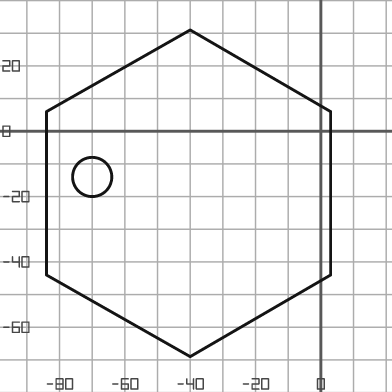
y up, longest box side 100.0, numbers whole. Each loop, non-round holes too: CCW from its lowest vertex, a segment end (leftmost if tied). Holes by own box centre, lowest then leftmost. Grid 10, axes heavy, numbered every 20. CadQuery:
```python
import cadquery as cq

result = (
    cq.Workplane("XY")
    .moveTo(-40.0, -69.0)
    .lineTo(3.0, -44.0)
    .lineTo(3.0, 6.0)
    .lineTo(-40.0, 31.0)
    .lineTo(-84.0, 6.0)
    .lineTo(-84.0, -44.0)
    .close()
    .moveTo(-70.0, -14.0)
    .circle(6.0)
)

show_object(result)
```